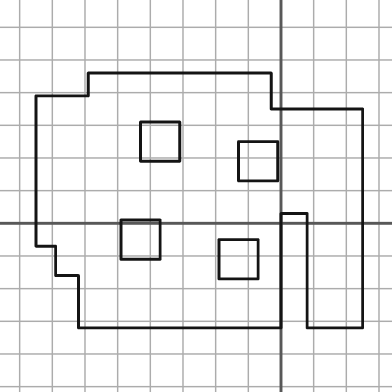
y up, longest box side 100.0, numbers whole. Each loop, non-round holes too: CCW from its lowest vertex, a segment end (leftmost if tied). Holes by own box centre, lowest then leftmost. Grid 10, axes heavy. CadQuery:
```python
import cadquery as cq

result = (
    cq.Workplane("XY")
    .moveTo(-62.0, -32.0)
    .lineTo(0.0, -32.0)
    .lineTo(0.0, 3.0)
    .lineTo(8.0, 3.0)
    .lineTo(8.0, -32.0)
    .lineTo(25.0, -32.0)
    .lineTo(25.0, 35.0)
    .lineTo(-3.0, 35.0)
    .lineTo(-3.0, 46.0)
    .lineTo(-59.0, 46.0)
    .lineTo(-59.0, 39.0)
    .lineTo(-75.0, 39.0)
    .lineTo(-75.0, -7.0)
    .lineTo(-69.0, -7.0)
    .lineTo(-69.0, -16.0)
    .lineTo(-62.0, -16.0)
    .close()
    .moveTo(-19.0, -17.0)
    .lineTo(-7.0, -17.0)
    .lineTo(-7.0, -5.0)
    .lineTo(-19.0, -5.0)
    .close()
    .moveTo(-49.0, -11.0)
    .lineTo(-37.0, -11.0)
    .lineTo(-37.0, 1.0)
    .lineTo(-49.0, 1.0)
    .close()
    .moveTo(-13.0, 13.0)
    .lineTo(-1.0, 13.0)
    .lineTo(-1.0, 25.0)
    .lineTo(-13.0, 25.0)
    .close()
    .moveTo(-43.0, 19.0)
    .lineTo(-31.0, 19.0)
    .lineTo(-31.0, 31.0)
    .lineTo(-43.0, 31.0)
    .close()
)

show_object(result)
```